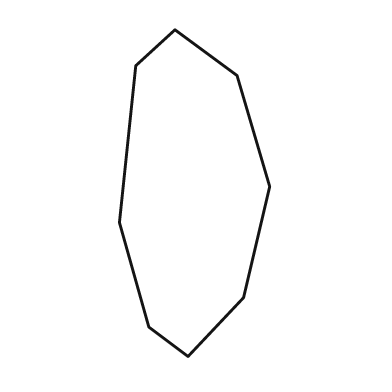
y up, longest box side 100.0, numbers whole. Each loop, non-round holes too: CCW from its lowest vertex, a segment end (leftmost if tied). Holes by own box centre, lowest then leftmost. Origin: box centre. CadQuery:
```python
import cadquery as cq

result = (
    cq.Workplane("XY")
    .moveTo(-2.0, -50.0)
    .lineTo(15.0, -32.0)
    .lineTo(23.0, 2.0)
    .lineTo(13.0, 36.0)
    .lineTo(-6.0, 50.0)
    .lineTo(-18.0, 39.0)
    .lineTo(-23.0, -9.0)
    .lineTo(-14.0, -41.0)
    .close()
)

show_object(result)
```